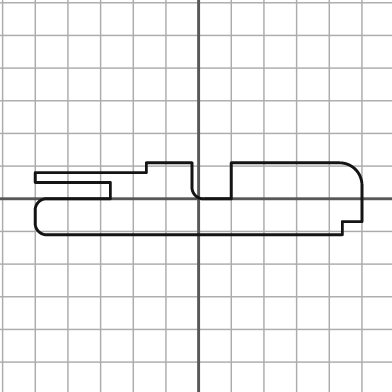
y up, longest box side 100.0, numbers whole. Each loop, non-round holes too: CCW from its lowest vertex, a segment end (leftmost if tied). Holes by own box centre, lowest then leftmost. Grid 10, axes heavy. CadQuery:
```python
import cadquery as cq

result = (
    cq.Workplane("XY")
    .moveTo(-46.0, -11.0)
    .lineTo(44.0, -11.0)
    .lineTo(44.0, -7.0)
    .lineTo(50.0, -7.0)
    .lineTo(50.0, 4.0)
    .threePointArc((48.0, 9.0), (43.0, 11.0))
    .lineTo(10.0, 11.0)
    .lineTo(10.0, 0.0)
    .lineTo(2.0, 0.0)
    .threePointArc((-1.0, 1.0), (-2.0, 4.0))
    .lineTo(-2.0, 11.0)
    .lineTo(-16.0, 11.0)
    .lineTo(-16.0, 8.0)
    .lineTo(-50.0, 8.0)
    .lineTo(-50.0, 5.0)
    .lineTo(-27.0, 5.0)
    .lineTo(-27.0, 0.0)
    .lineTo(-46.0, 0.0)
    .threePointArc((-49.0, -1.0), (-50.0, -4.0))
    .lineTo(-50.0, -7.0)
    .threePointArc((-49.0, -10.0), (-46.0, -11.0))
    .close()
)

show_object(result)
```